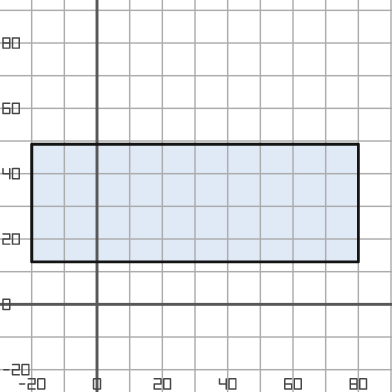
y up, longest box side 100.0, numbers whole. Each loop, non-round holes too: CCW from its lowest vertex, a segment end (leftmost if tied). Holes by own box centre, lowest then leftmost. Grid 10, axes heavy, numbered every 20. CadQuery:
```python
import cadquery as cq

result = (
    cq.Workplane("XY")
    .moveTo(-20.0, 13.0)
    .lineTo(80.0, 13.0)
    .lineTo(80.0, 49.0)
    .lineTo(-20.0, 49.0)
    .close()
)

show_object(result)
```